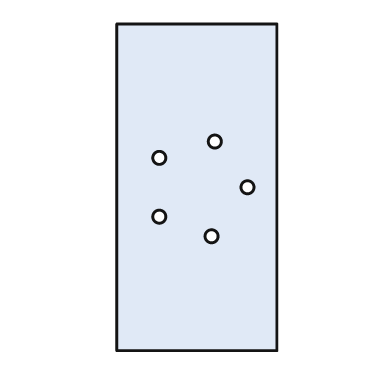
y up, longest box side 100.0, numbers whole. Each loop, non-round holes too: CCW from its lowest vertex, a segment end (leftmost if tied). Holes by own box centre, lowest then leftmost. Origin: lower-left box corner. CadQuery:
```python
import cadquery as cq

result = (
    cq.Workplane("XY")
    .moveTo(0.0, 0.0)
    .lineTo(49.0, 0.0)
    .lineTo(49.0, 100.0)
    .lineTo(0.0, 100.0)
    .close()
    .moveTo(29.0, 35.0)
    .circle(2.0)
    .moveTo(13.0, 41.0)
    .circle(2.0)
    .moveTo(40.0, 50.0)
    .circle(2.0)
    .moveTo(13.0, 59.0)
    .circle(2.0)
    .moveTo(30.0, 64.0)
    .circle(2.0)
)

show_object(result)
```